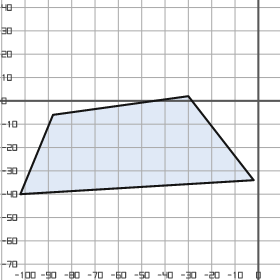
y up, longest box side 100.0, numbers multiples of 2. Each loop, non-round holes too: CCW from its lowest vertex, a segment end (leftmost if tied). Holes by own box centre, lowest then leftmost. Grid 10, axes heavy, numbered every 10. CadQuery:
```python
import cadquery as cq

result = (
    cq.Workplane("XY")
    .moveTo(-102.0, -40.0)
    .lineTo(-2.0, -34.0)
    .lineTo(-30.0, 2.0)
    .lineTo(-88.0, -6.0)
    .close()
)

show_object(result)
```